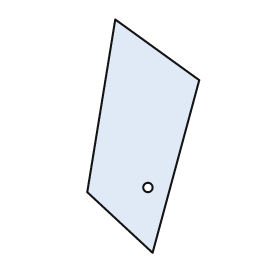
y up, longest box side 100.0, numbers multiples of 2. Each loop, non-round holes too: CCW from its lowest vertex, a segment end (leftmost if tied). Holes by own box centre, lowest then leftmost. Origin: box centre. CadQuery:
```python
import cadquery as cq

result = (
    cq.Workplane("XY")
    .moveTo(4.0, -50.0)
    .lineTo(24.0, 24.0)
    .lineTo(-12.0, 50.0)
    .lineTo(-24.0, -24.0)
    .close()
    .moveTo(2.0, -22.0)
    .circle(2.0)
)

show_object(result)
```